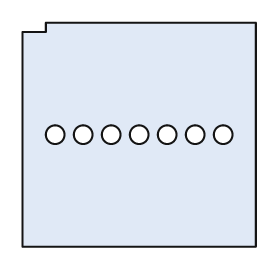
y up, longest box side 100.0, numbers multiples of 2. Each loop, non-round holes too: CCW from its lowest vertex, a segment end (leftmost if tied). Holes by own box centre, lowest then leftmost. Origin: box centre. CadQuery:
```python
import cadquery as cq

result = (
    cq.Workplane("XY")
    .moveTo(-50.0, -48.0)
    .lineTo(50.0, -48.0)
    .lineTo(50.0, 48.0)
    .lineTo(-40.0, 48.0)
    .lineTo(-40.0, 44.0)
    .lineTo(-50.0, 44.0)
    .close()
    .moveTo(-36.0, 0.0)
    .circle(4.0)
    .moveTo(-24.0, 0.0)
    .circle(4.0)
    .moveTo(-12.0, 0.0)
    .circle(4.0)
    .moveTo(0.0, 0.0)
    .circle(4.0)
    .moveTo(12.0, 0.0)
    .circle(4.0)
    .moveTo(24.0, 0.0)
    .circle(4.0)
    .moveTo(36.0, 0.0)
    .circle(4.0)
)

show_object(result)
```